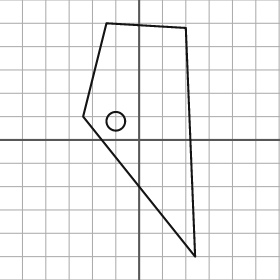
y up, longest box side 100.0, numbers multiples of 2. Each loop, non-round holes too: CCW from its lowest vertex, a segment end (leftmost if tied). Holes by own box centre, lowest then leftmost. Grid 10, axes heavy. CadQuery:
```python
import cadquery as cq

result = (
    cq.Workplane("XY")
    .moveTo(24.0, -50.0)
    .lineTo(20.0, 48.0)
    .lineTo(-14.0, 50.0)
    .lineTo(-24.0, 10.0)
    .close()
    .moveTo(-10.0, 8.0)
    .circle(4.0)
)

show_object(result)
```